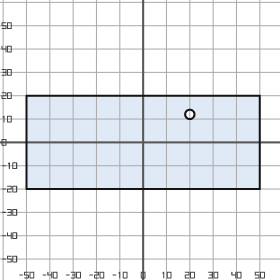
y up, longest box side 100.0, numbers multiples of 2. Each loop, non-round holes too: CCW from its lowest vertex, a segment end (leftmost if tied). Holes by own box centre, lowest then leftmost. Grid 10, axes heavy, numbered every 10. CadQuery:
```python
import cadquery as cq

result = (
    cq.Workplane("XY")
    .moveTo(-50.0, -20.0)
    .lineTo(50.0, -20.0)
    .lineTo(50.0, 20.0)
    .lineTo(-50.0, 20.0)
    .close()
    .moveTo(20.0, 12.0)
    .circle(2.0)
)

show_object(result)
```